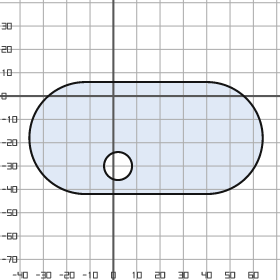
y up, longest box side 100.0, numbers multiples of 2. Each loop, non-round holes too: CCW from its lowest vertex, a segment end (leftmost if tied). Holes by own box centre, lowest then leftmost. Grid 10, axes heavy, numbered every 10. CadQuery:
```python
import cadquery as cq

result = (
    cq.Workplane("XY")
    .moveTo(-12.0, -42.0)
    .lineTo(40.0, -42.0)
    .threePointArc((64.0, -18.0), (40.0, 6.0))
    .lineTo(-12.0, 6.0)
    .threePointArc((-36.0, -18.0), (-12.0, -42.0))
    .close()
    .moveTo(2.0, -30.0)
    .circle(6.0)
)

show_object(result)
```